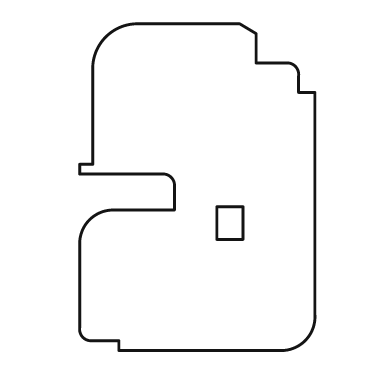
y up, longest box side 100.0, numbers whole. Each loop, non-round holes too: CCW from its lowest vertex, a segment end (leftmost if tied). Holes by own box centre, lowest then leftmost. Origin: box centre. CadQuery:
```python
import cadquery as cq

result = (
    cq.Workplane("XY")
    .moveTo(-24.0, -50.0)
    .lineTo(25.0, -50.0)
    .threePointArc((33.0, -47.0), (36.0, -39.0))
    .lineTo(36.0, 29.0)
    .lineTo(31.0, 29.0)
    .lineTo(31.0, 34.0)
    .threePointArc((30.0, 37.0), (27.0, 38.0))
    .lineTo(18.0, 38.0)
    .lineTo(18.0, 47.0)
    .lineTo(13.0, 50.0)
    .lineTo(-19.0, 50.0)
    .threePointArc((-28.0, 46.0), (-32.0, 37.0))
    .lineTo(-32.0, 7.0)
    .lineTo(-36.0, 7.0)
    .lineTo(-36.0, 4.0)
    .lineTo(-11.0, 4.0)
    .threePointArc((-8.0, 3.0), (-7.0, 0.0))
    .lineTo(-7.0, -7.0)
    .lineTo(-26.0, -7.0)
    .threePointArc((-33.0, -10.0), (-36.0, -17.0))
    .lineTo(-36.0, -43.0)
    .threePointArc((-35.0, -46.0), (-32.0, -47.0))
    .lineTo(-24.0, -47.0)
    .close()
    .moveTo(6.0, -16.0)
    .lineTo(14.0, -16.0)
    .lineTo(14.0, -6.0)
    .lineTo(6.0, -6.0)
    .close()
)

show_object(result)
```